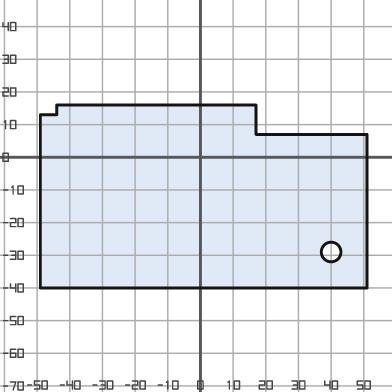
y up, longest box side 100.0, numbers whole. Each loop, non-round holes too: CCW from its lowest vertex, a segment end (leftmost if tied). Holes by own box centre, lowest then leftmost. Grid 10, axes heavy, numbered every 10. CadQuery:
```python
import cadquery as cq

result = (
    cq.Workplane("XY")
    .moveTo(-49.0, -40.0)
    .lineTo(51.0, -40.0)
    .lineTo(51.0, 7.0)
    .lineTo(17.0, 7.0)
    .lineTo(17.0, 16.0)
    .lineTo(-44.0, 16.0)
    .lineTo(-44.0, 13.0)
    .lineTo(-49.0, 13.0)
    .close()
    .moveTo(40.0, -29.0)
    .circle(3.0)
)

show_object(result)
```